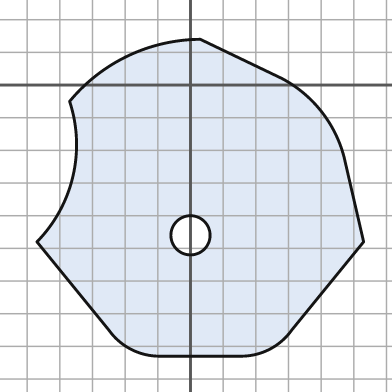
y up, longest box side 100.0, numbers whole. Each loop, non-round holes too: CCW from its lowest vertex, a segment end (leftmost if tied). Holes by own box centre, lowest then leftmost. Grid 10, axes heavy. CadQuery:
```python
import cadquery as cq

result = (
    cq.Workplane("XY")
    .moveTo(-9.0, -83.0)
    .lineTo(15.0, -83.0)
    .threePointArc((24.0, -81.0), (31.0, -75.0))
    .lineTo(53.0, -48.0)
    .lineTo(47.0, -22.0)
    .threePointArc((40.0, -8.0), (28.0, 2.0))
    .lineTo(3.0, 14.0)
    .threePointArc((-19.0, 9.0), (-37.0, -5.0))
    .threePointArc((-36.0, -28.0), (-47.0, -48.0))
    .lineTo(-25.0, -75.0)
    .threePointArc((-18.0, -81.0), (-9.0, -83.0))
    .close()
    .moveTo(0.0, -46.0)
    .circle(6.0)
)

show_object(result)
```